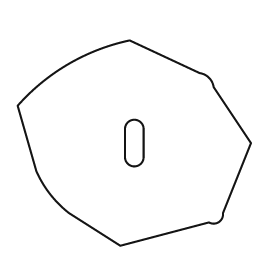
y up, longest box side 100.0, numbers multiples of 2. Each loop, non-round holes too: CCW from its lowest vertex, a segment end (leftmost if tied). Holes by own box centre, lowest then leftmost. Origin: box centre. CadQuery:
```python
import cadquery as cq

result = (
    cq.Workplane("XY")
    .moveTo(-6.0, -44.0)
    .lineTo(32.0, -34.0)
    .threePointArc((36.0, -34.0), (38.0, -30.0))
    .lineTo(50.0, 0.0)
    .lineTo(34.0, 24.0)
    .threePointArc((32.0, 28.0), (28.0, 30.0))
    .lineTo(-2.0, 44.0)
    .threePointArc((-28.0, 34.0), (-50.0, 16.0))
    .lineTo(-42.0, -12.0)
    .threePointArc((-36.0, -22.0), (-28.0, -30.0))
    .close()
    .moveTo(-4.0, -6.0)
    .threePointArc((0.0, -10.0), (4.0, -6.0))
    .lineTo(4.0, 6.0)
    .threePointArc((0.0, 10.0), (-4.0, 6.0))
    .close()
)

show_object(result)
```